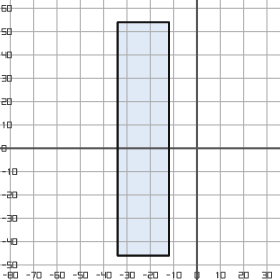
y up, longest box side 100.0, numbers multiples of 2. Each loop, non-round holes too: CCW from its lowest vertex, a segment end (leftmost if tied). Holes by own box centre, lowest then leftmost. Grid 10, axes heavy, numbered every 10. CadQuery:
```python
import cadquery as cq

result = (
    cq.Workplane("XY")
    .moveTo(-34.0, -46.0)
    .lineTo(-12.0, -46.0)
    .lineTo(-12.0, 54.0)
    .lineTo(-34.0, 54.0)
    .close()
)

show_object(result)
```